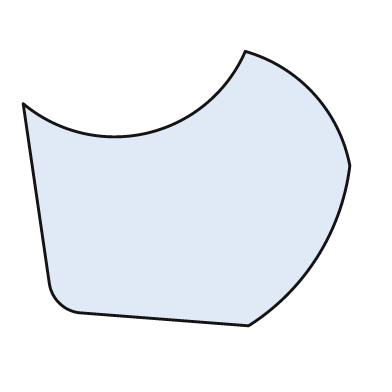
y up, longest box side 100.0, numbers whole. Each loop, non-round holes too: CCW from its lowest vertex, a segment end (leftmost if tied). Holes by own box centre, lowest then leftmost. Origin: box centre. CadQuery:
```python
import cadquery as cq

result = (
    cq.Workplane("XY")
    .moveTo(19.0, -42.0)
    .threePointArc((40.0, -21.0), (50.0, 7.0))
    .threePointArc((39.0, 29.0), (18.0, 42.0))
    .threePointArc((-12.0, 17.0), (-50.0, 26.0))
    .lineTo(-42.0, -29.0)
    .threePointArc((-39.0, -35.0), (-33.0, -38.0))
    .close()
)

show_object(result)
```